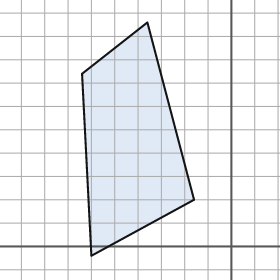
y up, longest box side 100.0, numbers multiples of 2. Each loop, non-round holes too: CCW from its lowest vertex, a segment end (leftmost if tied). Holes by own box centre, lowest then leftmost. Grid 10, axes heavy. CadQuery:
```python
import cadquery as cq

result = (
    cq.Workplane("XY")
    .moveTo(-60.0, -4.0)
    .lineTo(-16.0, 20.0)
    .lineTo(-36.0, 96.0)
    .lineTo(-64.0, 74.0)
    .close()
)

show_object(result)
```